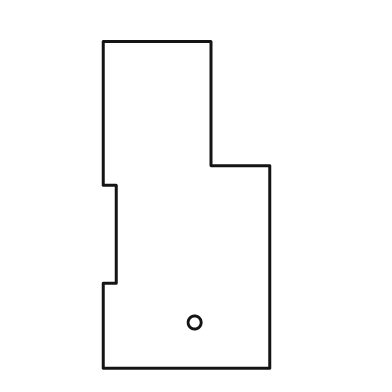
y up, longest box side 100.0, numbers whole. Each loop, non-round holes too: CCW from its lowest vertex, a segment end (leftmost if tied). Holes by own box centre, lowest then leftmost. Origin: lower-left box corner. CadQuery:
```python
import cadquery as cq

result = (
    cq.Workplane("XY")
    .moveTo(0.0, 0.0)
    .lineTo(51.0, 0.0)
    .lineTo(51.0, 62.0)
    .lineTo(33.0, 62.0)
    .lineTo(33.0, 100.0)
    .lineTo(0.0, 100.0)
    .lineTo(0.0, 56.0)
    .lineTo(4.0, 56.0)
    .lineTo(4.0, 26.0)
    .lineTo(0.0, 26.0)
    .close()
    .moveTo(28.0, 14.0)
    .circle(2.0)
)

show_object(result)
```